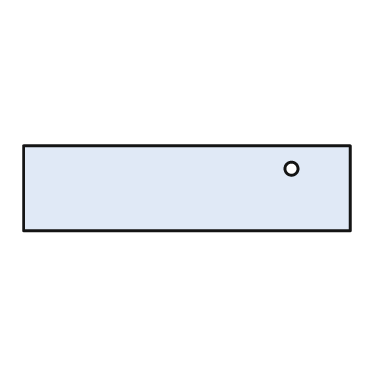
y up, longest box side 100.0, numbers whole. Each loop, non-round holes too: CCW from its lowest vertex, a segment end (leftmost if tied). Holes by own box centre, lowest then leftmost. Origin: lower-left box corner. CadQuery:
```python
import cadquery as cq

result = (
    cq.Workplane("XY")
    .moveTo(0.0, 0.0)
    .lineTo(100.0, 0.0)
    .lineTo(100.0, 26.0)
    .lineTo(0.0, 26.0)
    .close()
    .moveTo(82.0, 19.0)
    .circle(2.0)
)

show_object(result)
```